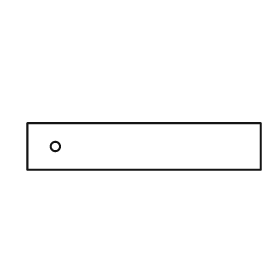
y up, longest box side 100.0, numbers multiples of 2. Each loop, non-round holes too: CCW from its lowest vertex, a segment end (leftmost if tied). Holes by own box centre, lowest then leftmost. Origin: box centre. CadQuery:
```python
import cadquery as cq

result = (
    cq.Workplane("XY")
    .moveTo(-50.0, -10.0)
    .lineTo(50.0, -10.0)
    .lineTo(50.0, 10.0)
    .lineTo(-50.0, 10.0)
    .close()
    .moveTo(-38.0, 0.0)
    .circle(2.0)
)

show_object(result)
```